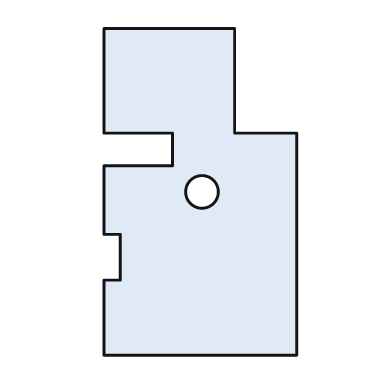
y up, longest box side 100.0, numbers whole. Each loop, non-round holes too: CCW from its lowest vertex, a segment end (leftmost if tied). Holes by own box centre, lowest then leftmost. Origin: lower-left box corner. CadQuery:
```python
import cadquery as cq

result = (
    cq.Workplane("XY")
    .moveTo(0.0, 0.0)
    .lineTo(59.0, 0.0)
    .lineTo(59.0, 68.0)
    .lineTo(40.0, 68.0)
    .lineTo(40.0, 100.0)
    .lineTo(0.0, 100.0)
    .lineTo(0.0, 68.0)
    .lineTo(21.0, 68.0)
    .lineTo(21.0, 58.0)
    .lineTo(0.0, 58.0)
    .lineTo(0.0, 37.0)
    .lineTo(5.0, 37.0)
    .lineTo(5.0, 23.0)
    .lineTo(0.0, 23.0)
    .close()
    .moveTo(30.0, 50.0)
    .circle(5.0)
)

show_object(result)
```